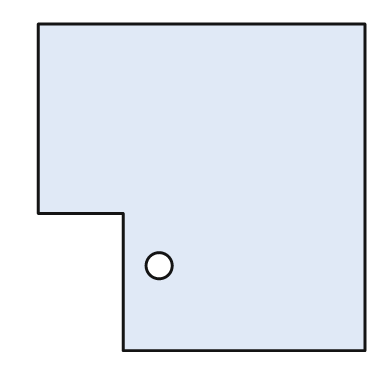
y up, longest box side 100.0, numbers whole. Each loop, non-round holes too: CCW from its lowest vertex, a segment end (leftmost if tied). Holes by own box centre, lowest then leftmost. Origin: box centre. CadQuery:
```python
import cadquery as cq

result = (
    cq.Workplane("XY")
    .moveTo(-24.0, -50.0)
    .lineTo(50.0, -50.0)
    .lineTo(50.0, 50.0)
    .lineTo(-50.0, 50.0)
    .lineTo(-50.0, -8.0)
    .lineTo(-24.0, -8.0)
    .close()
    .moveTo(-13.0, -24.0)
    .circle(4.0)
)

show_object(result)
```